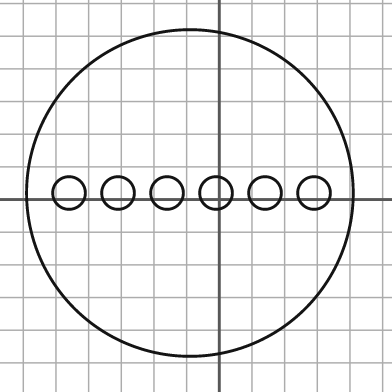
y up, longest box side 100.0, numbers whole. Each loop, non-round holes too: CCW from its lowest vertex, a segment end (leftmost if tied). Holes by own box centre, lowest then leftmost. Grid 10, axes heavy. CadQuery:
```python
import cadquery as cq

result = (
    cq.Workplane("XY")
    .moveTo(-9.0, 2.0)
    .circle(50.0)
    .moveTo(-46.0, 2.0)
    .circle(5.0)
    .moveTo(-31.0, 2.0)
    .circle(5.0)
    .moveTo(-16.0, 2.0)
    .circle(5.0)
    .moveTo(-1.0, 2.0)
    .circle(5.0)
    .moveTo(14.0, 2.0)
    .circle(5.0)
    .moveTo(29.0, 2.0)
    .circle(5.0)
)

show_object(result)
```